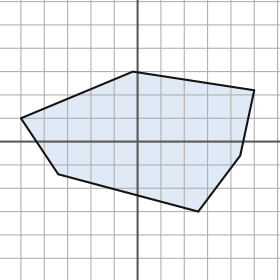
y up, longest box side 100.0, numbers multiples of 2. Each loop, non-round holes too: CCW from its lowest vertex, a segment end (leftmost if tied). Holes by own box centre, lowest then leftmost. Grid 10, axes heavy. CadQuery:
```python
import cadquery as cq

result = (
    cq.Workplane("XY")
    .moveTo(26.0, -30.0)
    .lineTo(44.0, -6.0)
    .lineTo(50.0, 22.0)
    .lineTo(-2.0, 30.0)
    .lineTo(-50.0, 10.0)
    .lineTo(-34.0, -14.0)
    .close()
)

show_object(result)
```